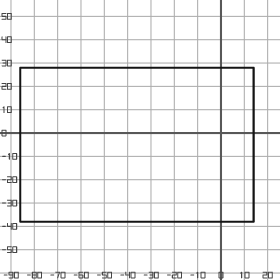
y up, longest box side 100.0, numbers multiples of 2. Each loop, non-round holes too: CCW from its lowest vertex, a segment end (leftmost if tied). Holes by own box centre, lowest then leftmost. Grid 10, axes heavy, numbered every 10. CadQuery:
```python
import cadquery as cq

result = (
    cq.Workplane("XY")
    .moveTo(-86.0, -38.0)
    .lineTo(14.0, -38.0)
    .lineTo(14.0, 28.0)
    .lineTo(-86.0, 28.0)
    .close()
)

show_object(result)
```